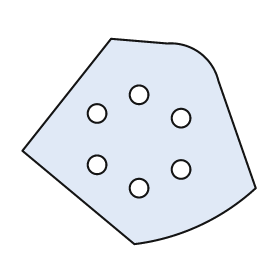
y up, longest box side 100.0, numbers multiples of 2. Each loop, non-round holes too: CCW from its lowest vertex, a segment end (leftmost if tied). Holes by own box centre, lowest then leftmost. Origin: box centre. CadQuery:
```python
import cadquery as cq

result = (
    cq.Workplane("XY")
    .moveTo(-2.0, -44.0)
    .threePointArc((26.0, -36.0), (50.0, -20.0))
    .lineTo(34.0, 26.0)
    .threePointArc((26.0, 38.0), (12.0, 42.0))
    .lineTo(-12.0, 44.0)
    .lineTo(-50.0, -4.0)
    .close()
    .moveTo(0.0, -20.0)
    .circle(4.0)
    .moveTo(18.0, -12.0)
    .circle(4.0)
    .moveTo(-18.0, -10.0)
    .circle(4.0)
    .moveTo(18.0, 10.0)
    .circle(4.0)
    .moveTo(-18.0, 12.0)
    .circle(4.0)
    .moveTo(0.0, 20.0)
    .circle(4.0)
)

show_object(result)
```